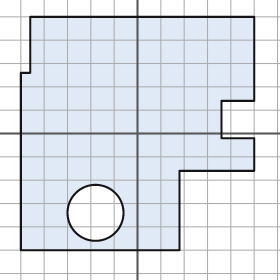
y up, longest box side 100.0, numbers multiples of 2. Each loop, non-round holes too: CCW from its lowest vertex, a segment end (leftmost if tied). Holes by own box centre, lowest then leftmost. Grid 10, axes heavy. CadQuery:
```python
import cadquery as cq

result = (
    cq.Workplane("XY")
    .moveTo(-50.0, -50.0)
    .lineTo(18.0, -50.0)
    .lineTo(18.0, -16.0)
    .lineTo(50.0, -16.0)
    .lineTo(50.0, -2.0)
    .lineTo(36.0, -2.0)
    .lineTo(36.0, 14.0)
    .lineTo(50.0, 14.0)
    .lineTo(50.0, 50.0)
    .lineTo(-46.0, 50.0)
    .lineTo(-46.0, 26.0)
    .lineTo(-50.0, 26.0)
    .close()
    .moveTo(-18.0, -34.0)
    .circle(12.0)
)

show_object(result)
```